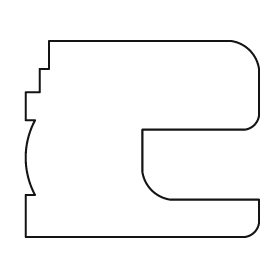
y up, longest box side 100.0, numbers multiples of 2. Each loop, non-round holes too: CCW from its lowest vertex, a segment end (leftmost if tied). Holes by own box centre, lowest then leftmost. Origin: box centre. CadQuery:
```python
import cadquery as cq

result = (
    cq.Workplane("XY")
    .moveTo(-50.0, -42.0)
    .lineTo(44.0, -42.0)
    .threePointArc((48.0, -40.0), (50.0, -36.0))
    .lineTo(50.0, -26.0)
    .lineTo(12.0, -26.0)
    .threePointArc((4.0, -22.0), (0.0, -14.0))
    .lineTo(0.0, 4.0)
    .lineTo(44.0, 4.0)
    .threePointArc((48.0, 6.0), (50.0, 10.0))
    .lineTo(50.0, 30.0)
    .threePointArc((46.0, 38.0), (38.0, 42.0))
    .lineTo(-40.0, 42.0)
    .lineTo(-40.0, 30.0)
    .lineTo(-44.0, 30.0)
    .lineTo(-44.0, 20.0)
    .lineTo(-50.0, 20.0)
    .lineTo(-50.0, 8.0)
    .lineTo(-46.0, 8.0)
    .threePointArc((-50.0, -8.0), (-46.0, -24.0))
    .lineTo(-50.0, -24.0)
    .close()
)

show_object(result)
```